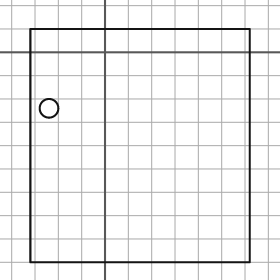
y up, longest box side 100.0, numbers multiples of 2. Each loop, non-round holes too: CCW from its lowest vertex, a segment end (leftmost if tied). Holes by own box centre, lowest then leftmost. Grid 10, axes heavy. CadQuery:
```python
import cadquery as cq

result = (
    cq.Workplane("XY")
    .moveTo(-32.0, -90.0)
    .lineTo(62.0, -90.0)
    .lineTo(62.0, 10.0)
    .lineTo(-32.0, 10.0)
    .close()
    .moveTo(-24.0, -24.0)
    .circle(4.0)
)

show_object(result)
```